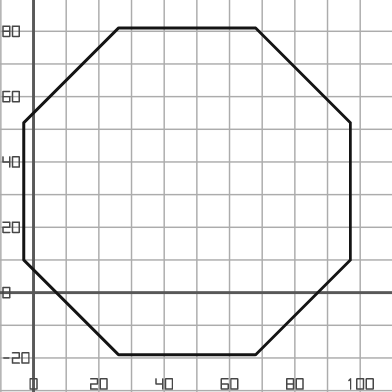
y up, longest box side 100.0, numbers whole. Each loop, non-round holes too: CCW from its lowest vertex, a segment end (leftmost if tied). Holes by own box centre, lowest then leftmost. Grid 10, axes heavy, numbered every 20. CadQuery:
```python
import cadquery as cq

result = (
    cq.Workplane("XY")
    .moveTo(26.0, -19.0)
    .lineTo(68.0, -19.0)
    .lineTo(97.0, 10.0)
    .lineTo(97.0, 52.0)
    .lineTo(68.0, 81.0)
    .lineTo(26.0, 81.0)
    .lineTo(-3.0, 52.0)
    .lineTo(-3.0, 10.0)
    .close()
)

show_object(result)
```